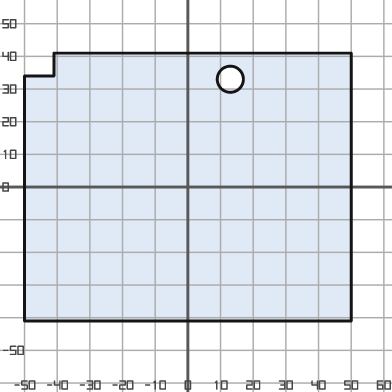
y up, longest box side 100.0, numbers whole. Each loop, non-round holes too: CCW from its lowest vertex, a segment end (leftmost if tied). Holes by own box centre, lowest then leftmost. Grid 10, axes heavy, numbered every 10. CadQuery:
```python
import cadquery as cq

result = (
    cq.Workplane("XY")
    .moveTo(-50.0, -41.0)
    .lineTo(50.0, -41.0)
    .lineTo(50.0, 41.0)
    .lineTo(-41.0, 41.0)
    .lineTo(-41.0, 34.0)
    .lineTo(-50.0, 34.0)
    .close()
    .moveTo(13.0, 33.0)
    .circle(4.0)
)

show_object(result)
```